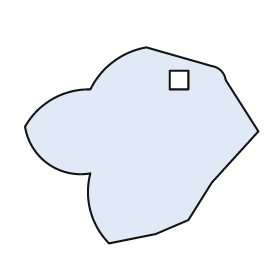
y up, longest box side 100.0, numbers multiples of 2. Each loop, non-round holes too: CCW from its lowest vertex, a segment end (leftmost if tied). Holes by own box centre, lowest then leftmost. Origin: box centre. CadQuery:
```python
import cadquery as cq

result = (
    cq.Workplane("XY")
    .moveTo(-14.0, -42.0)
    .lineTo(6.0, -38.0)
    .lineTo(20.0, -32.0)
    .lineTo(30.0, -16.0)
    .lineTo(50.0, 6.0)
    .lineTo(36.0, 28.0)
    .threePointArc((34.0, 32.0), (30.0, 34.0))
    .lineTo(2.0, 42.0)
    .threePointArc((-12.0, 36.0), (-22.0, 24.0))
    .threePointArc((-38.0, 20.0), (-50.0, 8.0))
    .threePointArc((-40.0, -8.0), (-22.0, -12.0))
    .threePointArc((-22.0, -28.0), (-14.0, -42.0))
    .close()
    .moveTo(12.0, 24.0)
    .lineTo(20.0, 24.0)
    .lineTo(20.0, 32.0)
    .lineTo(12.0, 32.0)
    .close()
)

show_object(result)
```